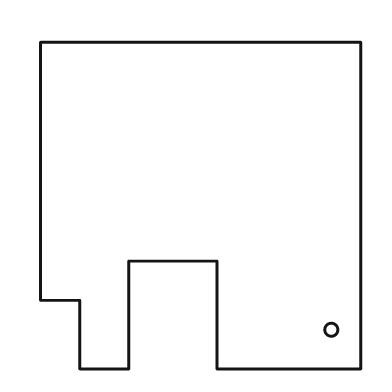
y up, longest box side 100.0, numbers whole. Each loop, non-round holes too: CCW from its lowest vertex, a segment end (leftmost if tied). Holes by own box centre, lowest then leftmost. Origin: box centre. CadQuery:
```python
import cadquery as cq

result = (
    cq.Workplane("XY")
    .moveTo(-37.0, -50.0)
    .lineTo(-22.0, -50.0)
    .lineTo(-22.0, -17.0)
    .lineTo(5.0, -17.0)
    .lineTo(5.0, -50.0)
    .lineTo(49.0, -50.0)
    .lineTo(49.0, 50.0)
    .lineTo(-49.0, 50.0)
    .lineTo(-49.0, -29.0)
    .lineTo(-37.0, -29.0)
    .close()
    .moveTo(40.0, -38.0)
    .circle(2.0)
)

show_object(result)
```